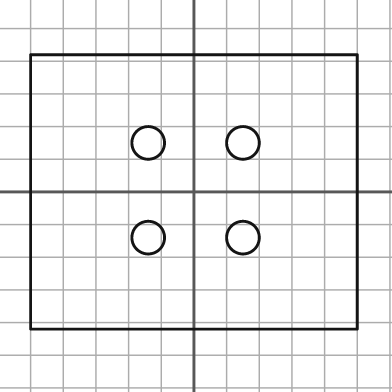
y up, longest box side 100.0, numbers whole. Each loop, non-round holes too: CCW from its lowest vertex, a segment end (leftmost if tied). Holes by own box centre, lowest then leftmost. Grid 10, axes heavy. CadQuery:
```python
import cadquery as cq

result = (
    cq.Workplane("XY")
    .moveTo(-50.0, -42.0)
    .lineTo(50.0, -42.0)
    .lineTo(50.0, 42.0)
    .lineTo(-50.0, 42.0)
    .close()
    .moveTo(-14.0, -14.0)
    .circle(5.0)
    .moveTo(15.0, -14.0)
    .circle(5.0)
    .moveTo(-14.0, 15.0)
    .circle(5.0)
    .moveTo(15.0, 15.0)
    .circle(5.0)
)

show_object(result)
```